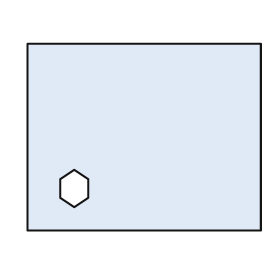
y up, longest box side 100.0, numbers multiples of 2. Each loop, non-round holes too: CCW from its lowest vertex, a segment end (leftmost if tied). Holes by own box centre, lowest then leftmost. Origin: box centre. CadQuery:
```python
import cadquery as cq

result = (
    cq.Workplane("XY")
    .moveTo(-50.0, -40.0)
    .lineTo(50.0, -40.0)
    .lineTo(50.0, 40.0)
    .lineTo(-50.0, 40.0)
    .close()
    .moveTo(-30.0, -30.0)
    .lineTo(-24.0, -26.0)
    .lineTo(-24.0, -18.0)
    .lineTo(-30.0, -14.0)
    .lineTo(-36.0, -18.0)
    .lineTo(-36.0, -26.0)
    .close()
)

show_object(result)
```